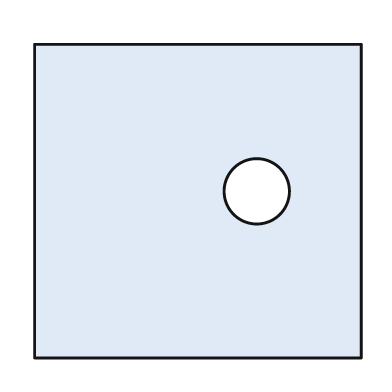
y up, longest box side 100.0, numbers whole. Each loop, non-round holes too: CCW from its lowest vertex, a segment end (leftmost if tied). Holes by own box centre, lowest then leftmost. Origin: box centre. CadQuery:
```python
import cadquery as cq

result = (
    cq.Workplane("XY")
    .moveTo(-50.0, -48.0)
    .lineTo(50.0, -48.0)
    .lineTo(50.0, 48.0)
    .lineTo(-50.0, 48.0)
    .close()
    .moveTo(18.0, 3.0)
    .circle(10.0)
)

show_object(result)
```